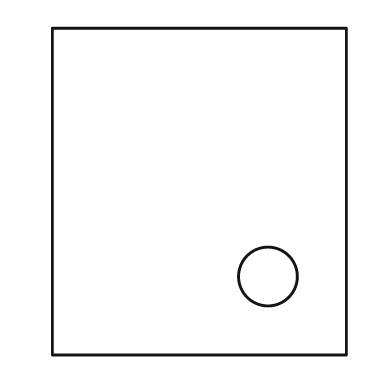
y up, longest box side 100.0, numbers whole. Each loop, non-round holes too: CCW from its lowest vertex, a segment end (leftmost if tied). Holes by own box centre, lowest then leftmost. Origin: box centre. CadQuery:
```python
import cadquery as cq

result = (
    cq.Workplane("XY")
    .moveTo(-45.0, -50.0)
    .lineTo(45.0, -50.0)
    .lineTo(45.0, 50.0)
    .lineTo(-45.0, 50.0)
    .close()
    .moveTo(21.0, -26.0)
    .circle(9.0)
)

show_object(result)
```